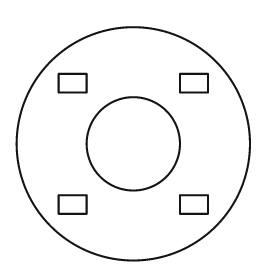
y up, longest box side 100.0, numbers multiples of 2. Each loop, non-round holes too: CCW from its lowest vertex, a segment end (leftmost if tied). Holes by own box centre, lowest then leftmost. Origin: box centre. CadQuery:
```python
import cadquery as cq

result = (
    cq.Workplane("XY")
    .moveTo(0.0, 0.0)
    .circle(50.0)
    .moveTo(-32.0, -30.0)
    .lineTo(-20.0, -30.0)
    .lineTo(-20.0, -22.0)
    .lineTo(-32.0, -22.0)
    .close()
    .moveTo(20.0, -30.0)
    .lineTo(32.0, -30.0)
    .lineTo(32.0, -22.0)
    .lineTo(20.0, -22.0)
    .close()
    .moveTo(0.0, 0.0)
    .circle(20.0)
    .moveTo(-32.0, 22.0)
    .lineTo(-20.0, 22.0)
    .lineTo(-20.0, 30.0)
    .lineTo(-32.0, 30.0)
    .close()
    .moveTo(20.0, 22.0)
    .lineTo(32.0, 22.0)
    .lineTo(32.0, 30.0)
    .lineTo(20.0, 30.0)
    .close()
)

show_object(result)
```